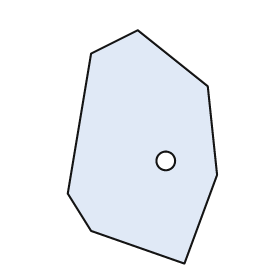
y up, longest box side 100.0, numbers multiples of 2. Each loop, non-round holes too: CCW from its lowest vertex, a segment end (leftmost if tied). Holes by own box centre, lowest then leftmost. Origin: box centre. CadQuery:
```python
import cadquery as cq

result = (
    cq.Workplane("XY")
    .moveTo(18.0, -50.0)
    .lineTo(32.0, -12.0)
    .lineTo(28.0, 26.0)
    .lineTo(-2.0, 50.0)
    .lineTo(-22.0, 40.0)
    .lineTo(-32.0, -20.0)
    .lineTo(-22.0, -36.0)
    .close()
    .moveTo(10.0, -6.0)
    .circle(4.0)
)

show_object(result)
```